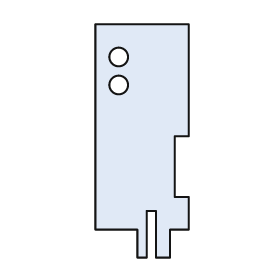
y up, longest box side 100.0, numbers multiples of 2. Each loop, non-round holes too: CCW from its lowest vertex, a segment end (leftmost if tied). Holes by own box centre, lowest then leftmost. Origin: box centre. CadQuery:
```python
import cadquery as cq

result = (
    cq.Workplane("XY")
    .moveTo(-2.0, -50.0)
    .lineTo(2.0, -50.0)
    .lineTo(2.0, -30.0)
    .lineTo(6.0, -30.0)
    .lineTo(6.0, -50.0)
    .lineTo(12.0, -50.0)
    .lineTo(12.0, -38.0)
    .lineTo(20.0, -38.0)
    .lineTo(20.0, -24.0)
    .lineTo(14.0, -24.0)
    .lineTo(14.0, 2.0)
    .lineTo(20.0, 2.0)
    .lineTo(20.0, 50.0)
    .lineTo(-20.0, 50.0)
    .lineTo(-20.0, -38.0)
    .lineTo(-2.0, -38.0)
    .close()
    .moveTo(-10.0, 24.0)
    .circle(4.0)
    .moveTo(-10.0, 36.0)
    .circle(4.0)
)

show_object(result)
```